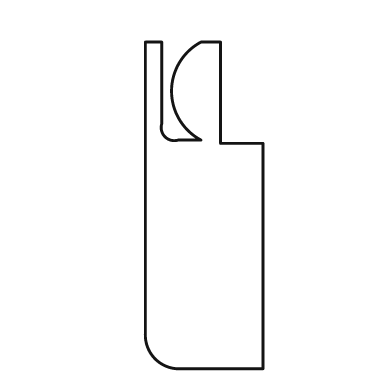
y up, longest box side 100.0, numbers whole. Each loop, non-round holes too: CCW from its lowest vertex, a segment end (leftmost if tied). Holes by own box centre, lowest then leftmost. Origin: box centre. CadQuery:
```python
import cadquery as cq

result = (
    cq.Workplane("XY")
    .moveTo(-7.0, -50.0)
    .lineTo(18.0, -50.0)
    .lineTo(18.0, 19.0)
    .lineTo(5.0, 19.0)
    .lineTo(5.0, 50.0)
    .lineTo(-1.0, 50.0)
    .threePointArc((-10.0, 35.0), (-1.0, 20.0))
    .lineTo(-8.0, 20.0)
    .threePointArc((-12.0, 21.0), (-13.0, 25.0))
    .lineTo(-13.0, 50.0)
    .lineTo(-18.0, 50.0)
    .lineTo(-18.0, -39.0)
    .threePointArc((-15.0, -47.0), (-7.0, -50.0))
    .close()
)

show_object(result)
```